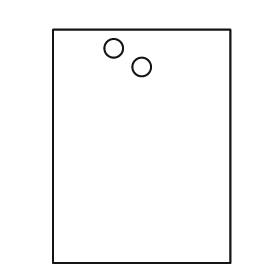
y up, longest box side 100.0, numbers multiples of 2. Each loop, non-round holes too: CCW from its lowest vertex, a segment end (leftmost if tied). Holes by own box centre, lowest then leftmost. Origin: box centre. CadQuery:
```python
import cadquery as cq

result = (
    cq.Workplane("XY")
    .moveTo(-38.0, -50.0)
    .lineTo(38.0, -50.0)
    .lineTo(38.0, 50.0)
    .lineTo(-38.0, 50.0)
    .close()
    .moveTo(0.0, 34.0)
    .circle(4.0)
    .moveTo(-12.0, 42.0)
    .circle(4.0)
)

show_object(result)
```